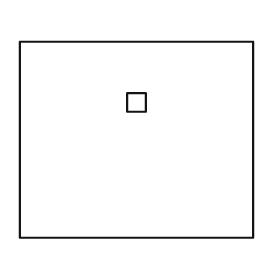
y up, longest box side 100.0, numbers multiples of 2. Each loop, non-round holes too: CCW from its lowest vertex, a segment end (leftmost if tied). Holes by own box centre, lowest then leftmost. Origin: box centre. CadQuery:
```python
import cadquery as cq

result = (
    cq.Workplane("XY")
    .moveTo(-50.0, -42.0)
    .lineTo(50.0, -42.0)
    .lineTo(50.0, 42.0)
    .lineTo(-50.0, 42.0)
    .close()
    .moveTo(-4.0, 12.0)
    .lineTo(4.0, 12.0)
    .lineTo(4.0, 20.0)
    .lineTo(-4.0, 20.0)
    .close()
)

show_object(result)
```